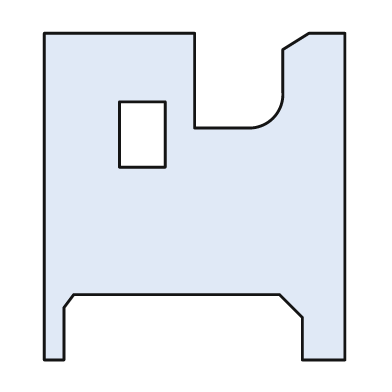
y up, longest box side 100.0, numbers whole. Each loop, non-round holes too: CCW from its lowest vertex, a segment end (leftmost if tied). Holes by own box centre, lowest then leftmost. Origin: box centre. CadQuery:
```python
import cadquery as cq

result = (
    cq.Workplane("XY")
    .moveTo(-46.0, -50.0)
    .lineTo(-40.0, -50.0)
    .lineTo(-40.0, -34.0)
    .lineTo(-37.0, -30.0)
    .lineTo(26.0, -30.0)
    .lineTo(33.0, -37.0)
    .lineTo(33.0, -50.0)
    .lineTo(46.0, -50.0)
    .lineTo(46.0, 50.0)
    .lineTo(35.0, 50.0)
    .lineTo(27.0, 45.0)
    .lineTo(27.0, 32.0)
    .threePointArc((24.0, 24.0), (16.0, 21.0))
    .lineTo(0.0, 21.0)
    .lineTo(0.0, 50.0)
    .lineTo(-46.0, 50.0)
    .close()
    .moveTo(-23.0, 9.0)
    .lineTo(-9.0, 9.0)
    .lineTo(-9.0, 29.0)
    .lineTo(-23.0, 29.0)
    .close()
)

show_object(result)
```